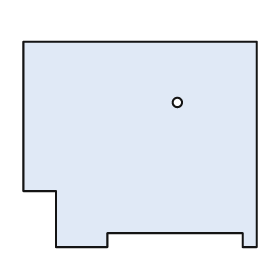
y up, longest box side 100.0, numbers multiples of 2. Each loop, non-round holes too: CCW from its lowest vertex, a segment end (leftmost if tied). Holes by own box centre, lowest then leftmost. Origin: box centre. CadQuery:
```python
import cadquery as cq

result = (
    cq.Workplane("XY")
    .moveTo(-36.0, -44.0)
    .lineTo(-14.0, -44.0)
    .lineTo(-14.0, -38.0)
    .lineTo(44.0, -38.0)
    .lineTo(44.0, -44.0)
    .lineTo(50.0, -44.0)
    .lineTo(50.0, 44.0)
    .lineTo(-50.0, 44.0)
    .lineTo(-50.0, -20.0)
    .lineTo(-36.0, -20.0)
    .close()
    .moveTo(16.0, 18.0)
    .circle(2.0)
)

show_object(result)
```